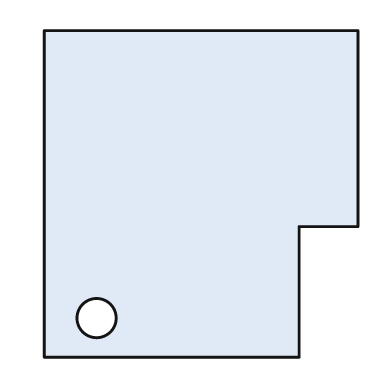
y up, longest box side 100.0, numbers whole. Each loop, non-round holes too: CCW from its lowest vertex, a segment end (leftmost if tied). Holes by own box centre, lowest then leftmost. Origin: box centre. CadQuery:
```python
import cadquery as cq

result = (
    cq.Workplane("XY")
    .moveTo(-48.0, -50.0)
    .lineTo(30.0, -50.0)
    .lineTo(30.0, -10.0)
    .lineTo(48.0, -10.0)
    .lineTo(48.0, 50.0)
    .lineTo(-48.0, 50.0)
    .close()
    .moveTo(-32.0, -38.0)
    .circle(6.0)
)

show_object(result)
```